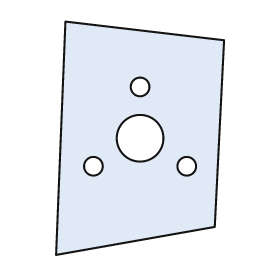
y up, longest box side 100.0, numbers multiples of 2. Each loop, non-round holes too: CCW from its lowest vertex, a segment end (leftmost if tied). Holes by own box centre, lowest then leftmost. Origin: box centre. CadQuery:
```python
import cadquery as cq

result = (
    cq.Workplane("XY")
    .moveTo(-36.0, -50.0)
    .lineTo(32.0, -38.0)
    .lineTo(36.0, 42.0)
    .lineTo(-32.0, 50.0)
    .close()
    .moveTo(-20.0, -12.0)
    .circle(4.0)
    .moveTo(20.0, -12.0)
    .circle(4.0)
    .moveTo(0.0, 0.0)
    .circle(10.0)
    .moveTo(0.0, 22.0)
    .circle(4.0)
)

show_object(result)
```